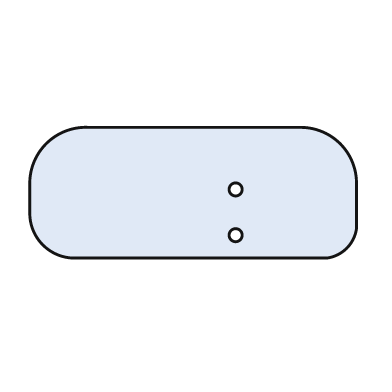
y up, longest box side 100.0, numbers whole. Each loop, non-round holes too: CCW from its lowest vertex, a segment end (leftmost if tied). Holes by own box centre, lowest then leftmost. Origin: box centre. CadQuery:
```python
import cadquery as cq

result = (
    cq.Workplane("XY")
    .moveTo(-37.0, -20.0)
    .lineTo(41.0, -20.0)
    .threePointArc((47.0, -17.0), (50.0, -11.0))
    .lineTo(50.0, 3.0)
    .threePointArc((45.0, 15.0), (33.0, 20.0))
    .lineTo(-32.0, 20.0)
    .threePointArc((-45.0, 15.0), (-50.0, 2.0))
    .lineTo(-50.0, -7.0)
    .threePointArc((-46.0, -16.0), (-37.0, -20.0))
    .close()
    .moveTo(13.0, -13.0)
    .circle(2.0)
    .moveTo(13.0, 1.0)
    .circle(2.0)
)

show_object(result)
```